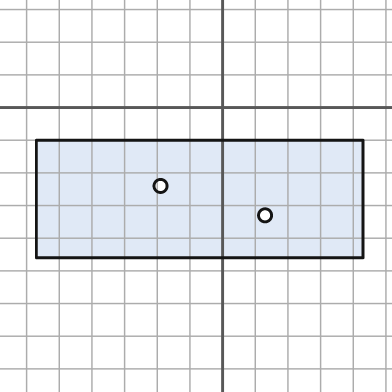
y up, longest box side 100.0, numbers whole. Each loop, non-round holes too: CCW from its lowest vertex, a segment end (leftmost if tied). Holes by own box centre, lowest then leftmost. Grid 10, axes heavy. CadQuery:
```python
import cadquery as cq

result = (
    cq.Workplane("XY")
    .moveTo(-57.0, -46.0)
    .lineTo(43.0, -46.0)
    .lineTo(43.0, -10.0)
    .lineTo(-57.0, -10.0)
    .close()
    .moveTo(13.0, -33.0)
    .circle(2.0)
    .moveTo(-19.0, -24.0)
    .circle(2.0)
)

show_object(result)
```